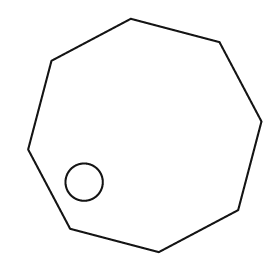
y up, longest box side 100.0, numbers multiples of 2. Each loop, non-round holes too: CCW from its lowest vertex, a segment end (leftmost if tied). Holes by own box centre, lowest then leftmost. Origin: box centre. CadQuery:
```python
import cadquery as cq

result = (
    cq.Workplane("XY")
    .moveTo(6.0, -50.0)
    .lineTo(40.0, -32.0)
    .lineTo(50.0, 6.0)
    .lineTo(32.0, 40.0)
    .lineTo(-6.0, 50.0)
    .lineTo(-40.0, 32.0)
    .lineTo(-50.0, -6.0)
    .lineTo(-32.0, -40.0)
    .close()
    .moveTo(-26.0, -20.0)
    .circle(8.0)
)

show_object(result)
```